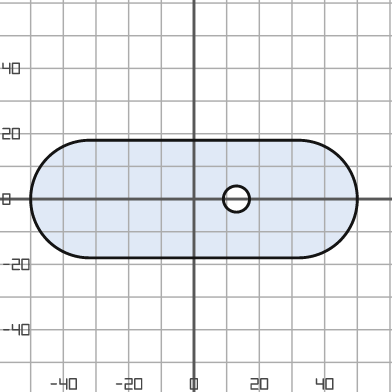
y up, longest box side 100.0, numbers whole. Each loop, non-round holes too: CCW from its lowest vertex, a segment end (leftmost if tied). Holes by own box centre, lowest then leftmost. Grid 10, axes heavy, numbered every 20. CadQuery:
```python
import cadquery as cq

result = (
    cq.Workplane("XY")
    .moveTo(-32.0, -18.0)
    .lineTo(32.0, -18.0)
    .threePointArc((50.0, 0.0), (32.0, 18.0))
    .lineTo(-32.0, 18.0)
    .threePointArc((-50.0, 0.0), (-32.0, -18.0))
    .close()
    .moveTo(13.0, 0.0)
    .circle(4.0)
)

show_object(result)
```